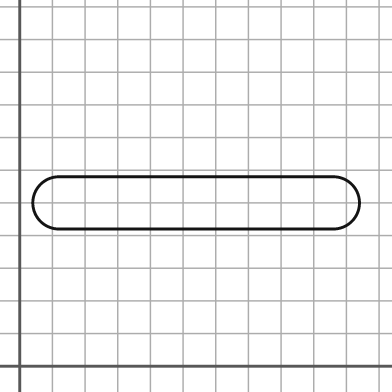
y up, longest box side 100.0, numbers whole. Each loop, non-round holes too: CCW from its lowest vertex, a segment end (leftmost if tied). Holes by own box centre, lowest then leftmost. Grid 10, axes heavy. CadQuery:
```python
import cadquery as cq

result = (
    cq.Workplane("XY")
    .moveTo(12.0, 42.0)
    .lineTo(96.0, 42.0)
    .threePointArc((104.0, 50.0), (96.0, 58.0))
    .lineTo(12.0, 58.0)
    .threePointArc((4.0, 50.0), (12.0, 42.0))
    .close()
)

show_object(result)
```